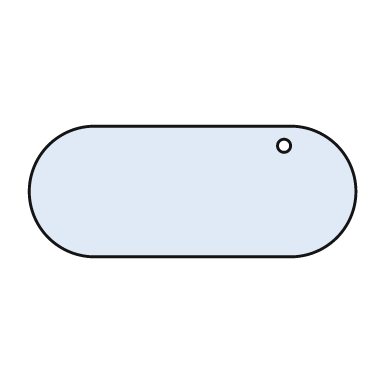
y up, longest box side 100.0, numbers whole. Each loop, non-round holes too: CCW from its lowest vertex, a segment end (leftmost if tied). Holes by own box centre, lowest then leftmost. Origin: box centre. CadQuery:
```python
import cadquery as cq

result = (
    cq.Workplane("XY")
    .moveTo(-30.0, -20.0)
    .lineTo(30.0, -20.0)
    .threePointArc((50.0, 0.0), (30.0, 20.0))
    .lineTo(-30.0, 20.0)
    .threePointArc((-50.0, 0.0), (-30.0, -20.0))
    .close()
    .moveTo(28.0, 14.0)
    .circle(2.0)
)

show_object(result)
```